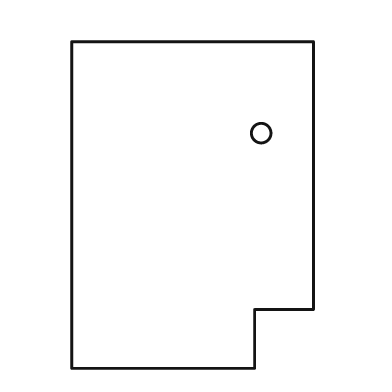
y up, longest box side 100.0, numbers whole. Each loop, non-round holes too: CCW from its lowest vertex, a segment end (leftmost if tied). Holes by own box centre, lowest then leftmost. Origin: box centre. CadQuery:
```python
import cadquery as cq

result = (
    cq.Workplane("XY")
    .moveTo(-37.0, -50.0)
    .lineTo(19.0, -50.0)
    .lineTo(19.0, -32.0)
    .lineTo(37.0, -32.0)
    .lineTo(37.0, 50.0)
    .lineTo(-37.0, 50.0)
    .close()
    .moveTo(21.0, 22.0)
    .circle(3.0)
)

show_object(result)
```